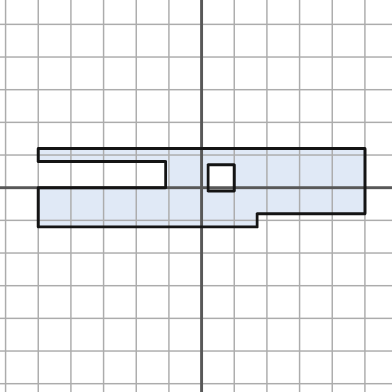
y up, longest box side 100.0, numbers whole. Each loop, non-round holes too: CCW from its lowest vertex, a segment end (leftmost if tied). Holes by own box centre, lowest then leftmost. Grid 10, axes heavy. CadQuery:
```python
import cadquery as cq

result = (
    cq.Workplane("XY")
    .moveTo(-50.0, -12.0)
    .lineTo(17.0, -12.0)
    .lineTo(17.0, -8.0)
    .lineTo(50.0, -8.0)
    .lineTo(50.0, 12.0)
    .lineTo(-50.0, 12.0)
    .lineTo(-50.0, 8.0)
    .lineTo(-11.0, 8.0)
    .lineTo(-11.0, 0.0)
    .lineTo(-50.0, 0.0)
    .close()
    .moveTo(2.0, -1.0)
    .lineTo(10.0, -1.0)
    .lineTo(10.0, 7.0)
    .lineTo(2.0, 7.0)
    .close()
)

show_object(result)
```